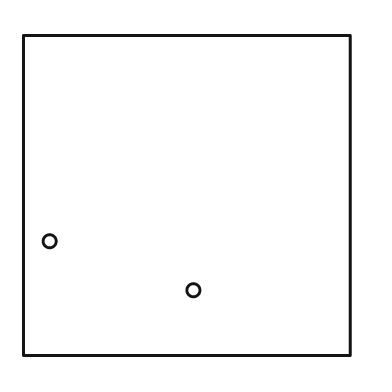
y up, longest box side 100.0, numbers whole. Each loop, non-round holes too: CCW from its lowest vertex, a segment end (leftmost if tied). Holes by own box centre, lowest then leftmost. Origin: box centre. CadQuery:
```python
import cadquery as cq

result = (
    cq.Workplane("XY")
    .moveTo(-50.0, -49.0)
    .lineTo(50.0, -49.0)
    .lineTo(50.0, 49.0)
    .lineTo(-50.0, 49.0)
    .close()
    .moveTo(2.0, -29.0)
    .circle(2.0)
    .moveTo(-42.0, -14.0)
    .circle(2.0)
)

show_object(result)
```